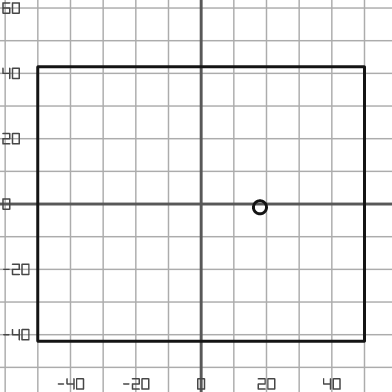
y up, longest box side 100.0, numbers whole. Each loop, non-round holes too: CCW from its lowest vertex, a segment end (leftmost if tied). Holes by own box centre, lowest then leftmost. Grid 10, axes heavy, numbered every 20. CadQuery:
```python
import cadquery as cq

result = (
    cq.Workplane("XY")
    .moveTo(-50.0, -42.0)
    .lineTo(50.0, -42.0)
    .lineTo(50.0, 42.0)
    .lineTo(-50.0, 42.0)
    .close()
    .moveTo(18.0, -1.0)
    .circle(2.0)
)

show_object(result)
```